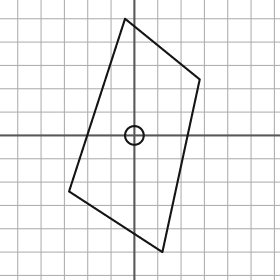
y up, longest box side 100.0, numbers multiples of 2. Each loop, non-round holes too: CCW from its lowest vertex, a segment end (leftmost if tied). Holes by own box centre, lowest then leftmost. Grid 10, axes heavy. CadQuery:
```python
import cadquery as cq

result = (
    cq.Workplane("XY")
    .moveTo(12.0, -50.0)
    .lineTo(28.0, 24.0)
    .lineTo(-4.0, 50.0)
    .lineTo(-28.0, -24.0)
    .close()
    .moveTo(0.0, 0.0)
    .circle(4.0)
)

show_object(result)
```